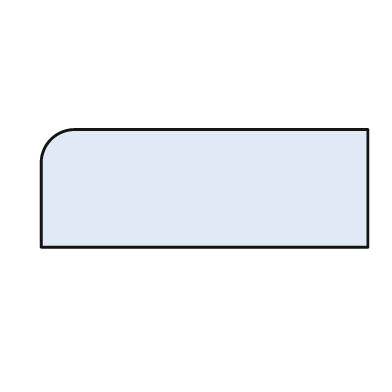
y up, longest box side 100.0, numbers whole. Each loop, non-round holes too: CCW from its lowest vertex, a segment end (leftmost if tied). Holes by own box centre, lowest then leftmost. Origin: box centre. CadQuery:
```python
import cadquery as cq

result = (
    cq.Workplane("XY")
    .moveTo(-50.0, -18.0)
    .lineTo(50.0, -18.0)
    .lineTo(50.0, 18.0)
    .lineTo(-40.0, 18.0)
    .threePointArc((-47.0, 15.0), (-50.0, 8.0))
    .close()
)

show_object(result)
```